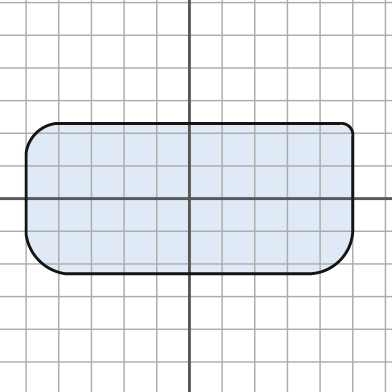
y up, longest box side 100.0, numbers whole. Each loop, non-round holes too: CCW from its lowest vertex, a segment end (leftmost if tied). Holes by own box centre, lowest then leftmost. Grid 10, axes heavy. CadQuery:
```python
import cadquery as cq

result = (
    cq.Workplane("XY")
    .moveTo(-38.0, -23.0)
    .lineTo(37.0, -23.0)
    .threePointArc((46.0, -19.0), (50.0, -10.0))
    .lineTo(50.0, 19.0)
    .threePointArc((49.0, 22.0), (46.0, 23.0))
    .lineTo(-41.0, 23.0)
    .threePointArc((-47.0, 20.0), (-50.0, 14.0))
    .lineTo(-50.0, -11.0)
    .threePointArc((-46.0, -19.0), (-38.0, -23.0))
    .close()
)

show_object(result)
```